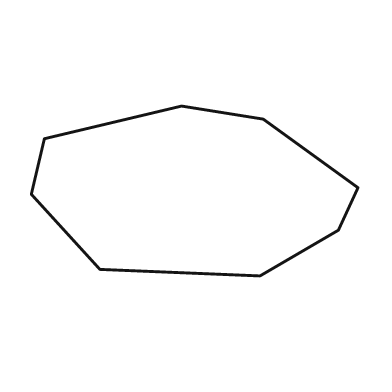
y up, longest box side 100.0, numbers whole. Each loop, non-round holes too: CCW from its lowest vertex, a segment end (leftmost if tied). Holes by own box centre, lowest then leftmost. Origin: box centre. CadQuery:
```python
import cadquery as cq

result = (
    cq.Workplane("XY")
    .moveTo(20.0, -26.0)
    .lineTo(44.0, -12.0)
    .lineTo(50.0, 1.0)
    .lineTo(21.0, 22.0)
    .lineTo(-4.0, 26.0)
    .lineTo(-46.0, 16.0)
    .lineTo(-50.0, -1.0)
    .lineTo(-29.0, -24.0)
    .close()
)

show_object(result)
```